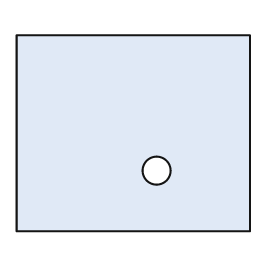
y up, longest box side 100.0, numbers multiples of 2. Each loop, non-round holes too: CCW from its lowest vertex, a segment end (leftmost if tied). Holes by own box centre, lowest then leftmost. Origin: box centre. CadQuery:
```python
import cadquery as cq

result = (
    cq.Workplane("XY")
    .moveTo(-50.0, -42.0)
    .lineTo(50.0, -42.0)
    .lineTo(50.0, 42.0)
    .lineTo(-50.0, 42.0)
    .close()
    .moveTo(10.0, -16.0)
    .circle(6.0)
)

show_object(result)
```